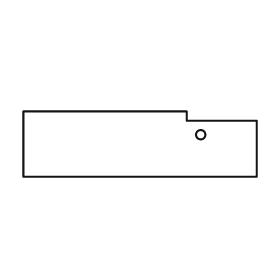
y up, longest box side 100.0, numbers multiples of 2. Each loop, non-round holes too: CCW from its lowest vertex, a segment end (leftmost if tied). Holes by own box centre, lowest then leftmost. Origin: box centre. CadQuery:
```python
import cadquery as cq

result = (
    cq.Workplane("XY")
    .moveTo(-50.0, -14.0)
    .lineTo(50.0, -14.0)
    .lineTo(50.0, 10.0)
    .lineTo(20.0, 10.0)
    .lineTo(20.0, 14.0)
    .lineTo(-50.0, 14.0)
    .close()
    .moveTo(26.0, 4.0)
    .circle(2.0)
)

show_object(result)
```